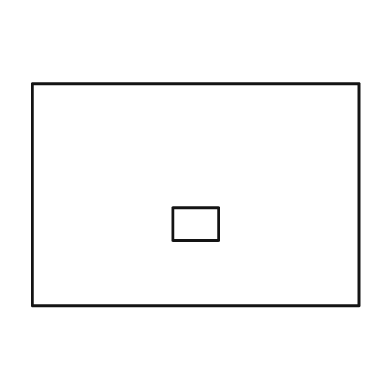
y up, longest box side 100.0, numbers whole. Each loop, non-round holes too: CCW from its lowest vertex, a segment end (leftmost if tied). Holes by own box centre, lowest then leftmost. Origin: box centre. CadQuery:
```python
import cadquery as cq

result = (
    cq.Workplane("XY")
    .moveTo(-50.0, -34.0)
    .lineTo(50.0, -34.0)
    .lineTo(50.0, 34.0)
    .lineTo(-50.0, 34.0)
    .close()
    .moveTo(-7.0, -14.0)
    .lineTo(7.0, -14.0)
    .lineTo(7.0, -4.0)
    .lineTo(-7.0, -4.0)
    .close()
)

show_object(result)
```